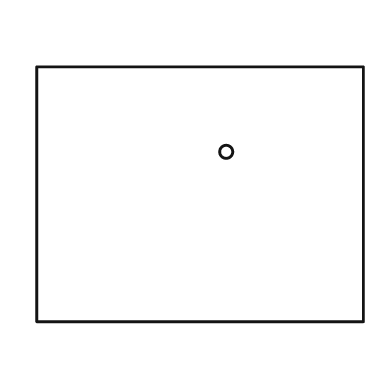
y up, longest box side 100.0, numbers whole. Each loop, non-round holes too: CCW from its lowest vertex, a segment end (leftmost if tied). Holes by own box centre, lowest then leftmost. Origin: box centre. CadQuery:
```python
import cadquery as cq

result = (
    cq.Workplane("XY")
    .moveTo(-50.0, -39.0)
    .lineTo(50.0, -39.0)
    .lineTo(50.0, 39.0)
    .lineTo(-50.0, 39.0)
    .close()
    .moveTo(8.0, 13.0)
    .circle(2.0)
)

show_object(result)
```